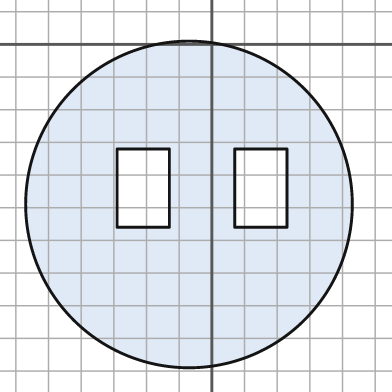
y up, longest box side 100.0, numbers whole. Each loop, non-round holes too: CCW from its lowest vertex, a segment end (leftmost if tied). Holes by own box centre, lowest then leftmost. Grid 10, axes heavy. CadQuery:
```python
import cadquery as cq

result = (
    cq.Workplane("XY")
    .moveTo(-7.0, -49.0)
    .circle(50.0)
    .moveTo(-29.0, -56.0)
    .lineTo(-13.0, -56.0)
    .lineTo(-13.0, -32.0)
    .lineTo(-29.0, -32.0)
    .close()
    .moveTo(7.0, -56.0)
    .lineTo(23.0, -56.0)
    .lineTo(23.0, -32.0)
    .lineTo(7.0, -32.0)
    .close()
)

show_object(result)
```